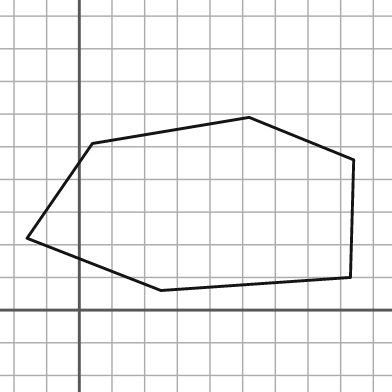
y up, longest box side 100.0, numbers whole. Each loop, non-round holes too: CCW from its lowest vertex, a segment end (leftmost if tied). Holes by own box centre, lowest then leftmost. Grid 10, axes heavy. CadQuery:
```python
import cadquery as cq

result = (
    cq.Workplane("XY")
    .moveTo(25.0, 6.0)
    .lineTo(83.0, 10.0)
    .lineTo(84.0, 46.0)
    .lineTo(52.0, 59.0)
    .lineTo(4.0, 51.0)
    .lineTo(-16.0, 22.0)
    .close()
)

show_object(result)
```